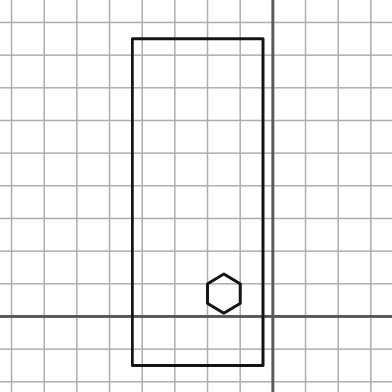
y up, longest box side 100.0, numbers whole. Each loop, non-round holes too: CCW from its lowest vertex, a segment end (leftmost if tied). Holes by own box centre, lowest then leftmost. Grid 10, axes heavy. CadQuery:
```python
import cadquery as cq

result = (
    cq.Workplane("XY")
    .moveTo(-43.0, -15.0)
    .lineTo(-3.0, -15.0)
    .lineTo(-3.0, 85.0)
    .lineTo(-43.0, 85.0)
    .close()
    .moveTo(-15.0, 1.0)
    .lineTo(-10.0, 4.0)
    .lineTo(-10.0, 10.0)
    .lineTo(-15.0, 13.0)
    .lineTo(-20.0, 10.0)
    .lineTo(-20.0, 4.0)
    .close()
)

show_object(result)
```